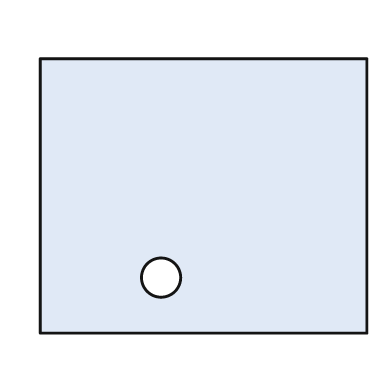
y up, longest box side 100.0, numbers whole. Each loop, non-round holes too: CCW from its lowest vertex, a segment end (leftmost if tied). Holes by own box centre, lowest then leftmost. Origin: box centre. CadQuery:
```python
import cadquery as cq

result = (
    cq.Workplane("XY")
    .moveTo(-50.0, -42.0)
    .lineTo(50.0, -42.0)
    .lineTo(50.0, 42.0)
    .lineTo(-50.0, 42.0)
    .close()
    .moveTo(-13.0, -25.0)
    .circle(6.0)
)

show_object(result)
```